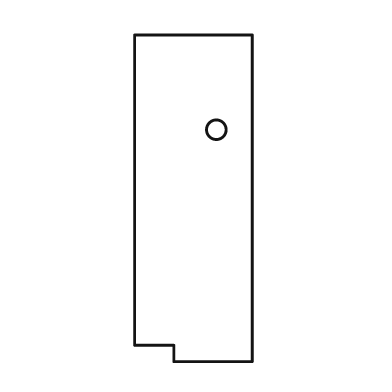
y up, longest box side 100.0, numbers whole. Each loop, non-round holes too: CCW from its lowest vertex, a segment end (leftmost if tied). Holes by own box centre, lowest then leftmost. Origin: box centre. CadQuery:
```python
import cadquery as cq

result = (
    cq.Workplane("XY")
    .moveTo(-6.0, -50.0)
    .lineTo(18.0, -50.0)
    .lineTo(18.0, 50.0)
    .lineTo(-18.0, 50.0)
    .lineTo(-18.0, -45.0)
    .lineTo(-6.0, -45.0)
    .close()
    .moveTo(7.0, 21.0)
    .circle(3.0)
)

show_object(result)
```